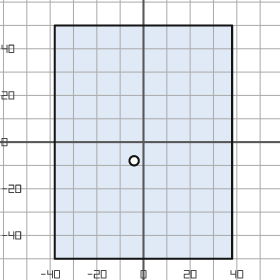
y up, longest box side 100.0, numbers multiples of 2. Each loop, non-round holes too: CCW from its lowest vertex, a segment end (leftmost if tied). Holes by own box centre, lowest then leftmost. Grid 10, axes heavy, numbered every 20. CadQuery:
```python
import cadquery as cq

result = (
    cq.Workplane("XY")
    .moveTo(-38.0, -50.0)
    .lineTo(38.0, -50.0)
    .lineTo(38.0, 50.0)
    .lineTo(-38.0, 50.0)
    .close()
    .moveTo(-4.0, -8.0)
    .circle(2.0)
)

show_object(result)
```